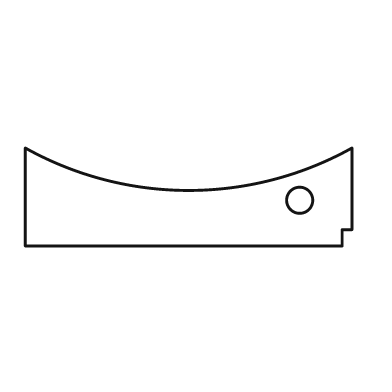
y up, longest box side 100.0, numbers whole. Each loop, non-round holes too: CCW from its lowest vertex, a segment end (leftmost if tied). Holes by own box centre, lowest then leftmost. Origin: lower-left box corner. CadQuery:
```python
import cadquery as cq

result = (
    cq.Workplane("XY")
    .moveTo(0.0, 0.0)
    .lineTo(97.0, 0.0)
    .lineTo(97.0, 5.0)
    .lineTo(100.0, 5.0)
    .lineTo(100.0, 30.0)
    .threePointArc((50.0, 17.0), (0.0, 30.0))
    .close()
    .moveTo(84.0, 14.0)
    .circle(4.0)
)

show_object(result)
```